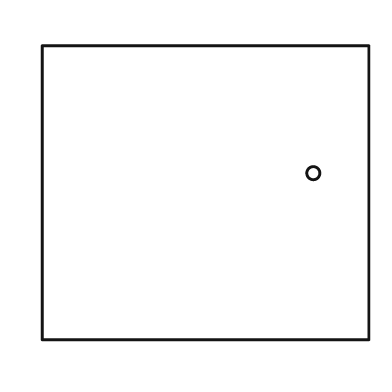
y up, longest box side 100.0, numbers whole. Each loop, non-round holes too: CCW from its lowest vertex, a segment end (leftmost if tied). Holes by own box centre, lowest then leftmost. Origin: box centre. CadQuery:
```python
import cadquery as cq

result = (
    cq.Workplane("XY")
    .moveTo(-50.0, -45.0)
    .lineTo(50.0, -45.0)
    .lineTo(50.0, 45.0)
    .lineTo(-50.0, 45.0)
    .close()
    .moveTo(33.0, 6.0)
    .circle(2.0)
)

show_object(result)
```